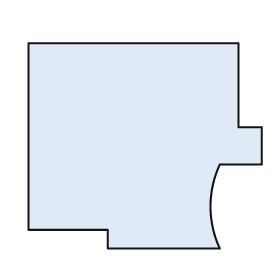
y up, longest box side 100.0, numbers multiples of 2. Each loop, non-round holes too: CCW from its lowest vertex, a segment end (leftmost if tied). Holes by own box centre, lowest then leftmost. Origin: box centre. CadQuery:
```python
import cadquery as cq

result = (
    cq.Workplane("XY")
    .moveTo(-16.0, -44.0)
    .lineTo(32.0, -44.0)
    .threePointArc((28.0, -26.0), (32.0, -8.0))
    .lineTo(50.0, -8.0)
    .lineTo(50.0, 8.0)
    .lineTo(40.0, 8.0)
    .lineTo(40.0, 44.0)
    .lineTo(-50.0, 44.0)
    .lineTo(-50.0, -36.0)
    .lineTo(-16.0, -36.0)
    .close()
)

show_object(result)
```